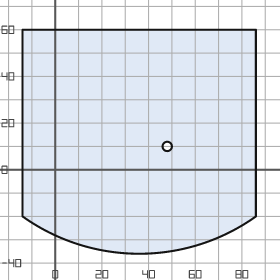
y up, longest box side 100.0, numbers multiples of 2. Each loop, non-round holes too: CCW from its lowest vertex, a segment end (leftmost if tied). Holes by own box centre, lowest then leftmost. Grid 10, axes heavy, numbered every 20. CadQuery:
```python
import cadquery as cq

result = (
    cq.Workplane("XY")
    .moveTo(-14.0, -20.0)
    .threePointArc((36.0, -36.0), (86.0, -20.0))
    .lineTo(86.0, 60.0)
    .lineTo(-14.0, 60.0)
    .close()
    .moveTo(48.0, 10.0)
    .circle(2.0)
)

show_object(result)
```